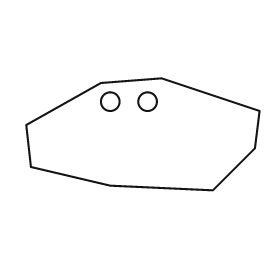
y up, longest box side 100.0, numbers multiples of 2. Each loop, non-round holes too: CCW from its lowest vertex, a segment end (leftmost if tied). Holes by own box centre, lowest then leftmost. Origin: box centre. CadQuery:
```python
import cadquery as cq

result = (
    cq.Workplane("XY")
    .moveTo(30.0, -24.0)
    .lineTo(48.0, -6.0)
    .lineTo(50.0, 10.0)
    .lineTo(8.0, 24.0)
    .lineTo(-18.0, 22.0)
    .lineTo(-50.0, 4.0)
    .lineTo(-48.0, -14.0)
    .lineTo(-14.0, -22.0)
    .close()
    .moveTo(-14.0, 14.0)
    .circle(4.0)
    .moveTo(2.0, 14.0)
    .circle(4.0)
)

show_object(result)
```